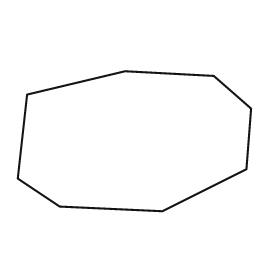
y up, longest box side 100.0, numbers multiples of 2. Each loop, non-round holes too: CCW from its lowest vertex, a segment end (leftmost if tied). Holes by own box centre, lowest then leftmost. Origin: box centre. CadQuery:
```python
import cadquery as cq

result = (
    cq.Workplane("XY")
    .moveTo(12.0, -30.0)
    .lineTo(48.0, -12.0)
    .lineTo(50.0, 14.0)
    .lineTo(34.0, 28.0)
    .lineTo(-4.0, 30.0)
    .lineTo(-46.0, 20.0)
    .lineTo(-50.0, -16.0)
    .lineTo(-32.0, -28.0)
    .close()
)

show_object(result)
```